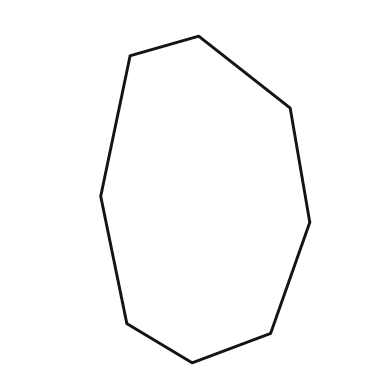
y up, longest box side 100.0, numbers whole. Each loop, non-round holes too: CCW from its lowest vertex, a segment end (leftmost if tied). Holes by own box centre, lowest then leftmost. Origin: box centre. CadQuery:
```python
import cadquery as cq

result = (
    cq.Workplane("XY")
    .moveTo(-4.0, -50.0)
    .lineTo(20.0, -41.0)
    .lineTo(32.0, -7.0)
    .lineTo(26.0, 28.0)
    .lineTo(-2.0, 50.0)
    .lineTo(-23.0, 44.0)
    .lineTo(-32.0, 1.0)
    .lineTo(-24.0, -38.0)
    .close()
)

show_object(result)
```